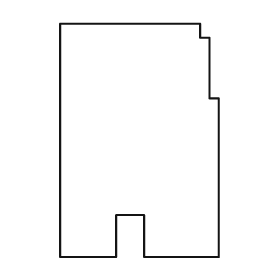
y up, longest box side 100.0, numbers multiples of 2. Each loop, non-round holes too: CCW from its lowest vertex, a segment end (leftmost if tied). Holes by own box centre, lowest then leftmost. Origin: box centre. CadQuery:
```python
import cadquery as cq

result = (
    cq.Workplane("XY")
    .moveTo(-34.0, -50.0)
    .lineTo(-10.0, -50.0)
    .lineTo(-10.0, -32.0)
    .lineTo(2.0, -32.0)
    .lineTo(2.0, -50.0)
    .lineTo(34.0, -50.0)
    .lineTo(34.0, 18.0)
    .lineTo(30.0, 18.0)
    .lineTo(30.0, 44.0)
    .lineTo(26.0, 44.0)
    .lineTo(26.0, 50.0)
    .lineTo(-34.0, 50.0)
    .close()
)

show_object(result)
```